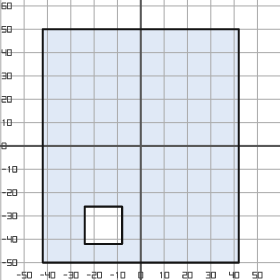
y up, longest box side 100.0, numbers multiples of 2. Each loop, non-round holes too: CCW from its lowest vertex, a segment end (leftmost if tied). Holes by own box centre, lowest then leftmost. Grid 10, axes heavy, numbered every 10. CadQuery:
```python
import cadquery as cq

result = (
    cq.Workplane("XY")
    .moveTo(-42.0, -50.0)
    .lineTo(42.0, -50.0)
    .lineTo(42.0, 50.0)
    .lineTo(-42.0, 50.0)
    .close()
    .moveTo(-24.0, -42.0)
    .lineTo(-8.0, -42.0)
    .lineTo(-8.0, -26.0)
    .lineTo(-24.0, -26.0)
    .close()
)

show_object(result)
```